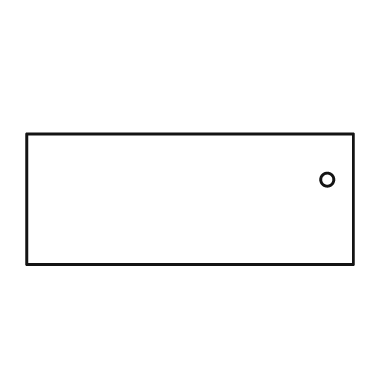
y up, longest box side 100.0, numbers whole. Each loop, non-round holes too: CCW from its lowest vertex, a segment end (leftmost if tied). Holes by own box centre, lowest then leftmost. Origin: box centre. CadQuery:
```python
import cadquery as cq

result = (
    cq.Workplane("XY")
    .moveTo(-50.0, -20.0)
    .lineTo(50.0, -20.0)
    .lineTo(50.0, 20.0)
    .lineTo(-50.0, 20.0)
    .close()
    .moveTo(42.0, 6.0)
    .circle(2.0)
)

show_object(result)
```